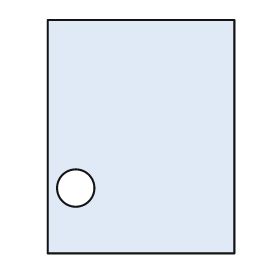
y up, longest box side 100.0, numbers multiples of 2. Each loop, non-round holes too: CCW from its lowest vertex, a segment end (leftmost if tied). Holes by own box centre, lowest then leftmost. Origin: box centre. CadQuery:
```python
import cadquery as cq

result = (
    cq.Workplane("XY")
    .moveTo(-40.0, -50.0)
    .lineTo(40.0, -50.0)
    .lineTo(40.0, 50.0)
    .lineTo(-40.0, 50.0)
    .close()
    .moveTo(-28.0, -22.0)
    .circle(8.0)
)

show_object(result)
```